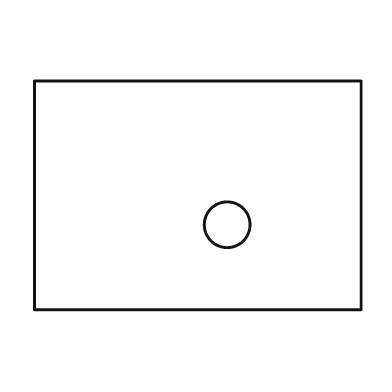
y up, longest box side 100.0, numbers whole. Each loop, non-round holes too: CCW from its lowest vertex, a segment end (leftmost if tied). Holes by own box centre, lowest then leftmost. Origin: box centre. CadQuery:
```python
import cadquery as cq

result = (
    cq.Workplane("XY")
    .moveTo(-50.0, -35.0)
    .lineTo(50.0, -35.0)
    .lineTo(50.0, 35.0)
    .lineTo(-50.0, 35.0)
    .close()
    .moveTo(9.0, -9.0)
    .circle(7.0)
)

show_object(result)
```